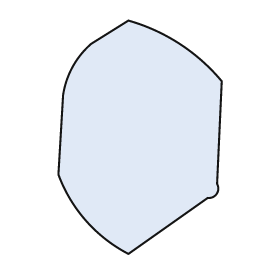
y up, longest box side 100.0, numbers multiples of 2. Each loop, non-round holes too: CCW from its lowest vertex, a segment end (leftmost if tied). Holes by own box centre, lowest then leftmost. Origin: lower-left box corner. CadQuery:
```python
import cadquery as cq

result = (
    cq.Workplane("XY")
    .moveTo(30.0, 0.0)
    .lineTo(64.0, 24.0)
    .threePointArc((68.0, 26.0), (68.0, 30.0))
    .lineTo(70.0, 74.0)
    .threePointArc((52.0, 90.0), (30.0, 100.0))
    .lineTo(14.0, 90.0)
    .threePointArc((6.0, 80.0), (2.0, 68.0))
    .lineTo(0.0, 34.0)
    .threePointArc((12.0, 14.0), (30.0, 0.0))
    .close()
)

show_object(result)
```